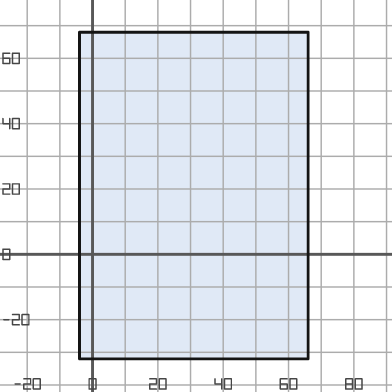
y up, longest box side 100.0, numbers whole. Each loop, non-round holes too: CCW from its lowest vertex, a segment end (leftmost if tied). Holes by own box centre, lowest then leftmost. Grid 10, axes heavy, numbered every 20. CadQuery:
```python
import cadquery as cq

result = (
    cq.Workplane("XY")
    .moveTo(-4.0, -32.0)
    .lineTo(66.0, -32.0)
    .lineTo(66.0, 68.0)
    .lineTo(-4.0, 68.0)
    .close()
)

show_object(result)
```